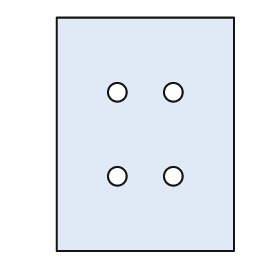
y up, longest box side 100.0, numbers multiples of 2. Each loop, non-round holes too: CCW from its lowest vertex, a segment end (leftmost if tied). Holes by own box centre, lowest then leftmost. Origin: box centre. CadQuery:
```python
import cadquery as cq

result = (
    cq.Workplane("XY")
    .moveTo(-38.0, -50.0)
    .lineTo(38.0, -50.0)
    .lineTo(38.0, 50.0)
    .lineTo(-38.0, 50.0)
    .close()
    .moveTo(-12.0, -18.0)
    .circle(4.0)
    .moveTo(12.0, -18.0)
    .circle(4.0)
    .moveTo(-12.0, 18.0)
    .circle(4.0)
    .moveTo(12.0, 18.0)
    .circle(4.0)
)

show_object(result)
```